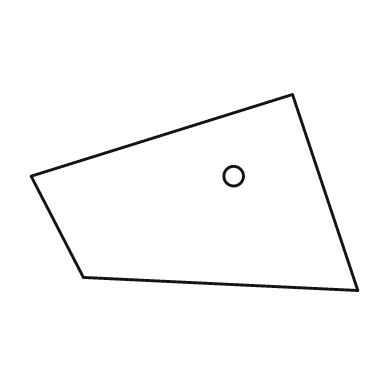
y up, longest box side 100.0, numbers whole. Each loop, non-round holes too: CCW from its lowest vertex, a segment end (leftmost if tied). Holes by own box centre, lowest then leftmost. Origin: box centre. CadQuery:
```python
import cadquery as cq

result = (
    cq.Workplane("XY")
    .moveTo(50.0, -30.0)
    .lineTo(30.0, 30.0)
    .lineTo(-50.0, 5.0)
    .lineTo(-34.0, -26.0)
    .close()
    .moveTo(12.0, 5.0)
    .circle(3.0)
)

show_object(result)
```